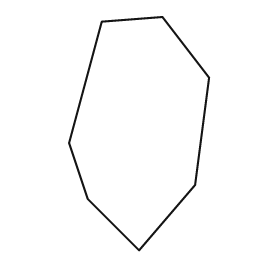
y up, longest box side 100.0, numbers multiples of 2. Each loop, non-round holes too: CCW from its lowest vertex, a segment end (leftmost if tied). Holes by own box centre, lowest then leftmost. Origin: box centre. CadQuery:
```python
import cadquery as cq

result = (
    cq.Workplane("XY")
    .moveTo(0.0, -50.0)
    .lineTo(24.0, -22.0)
    .lineTo(30.0, 24.0)
    .lineTo(10.0, 50.0)
    .lineTo(-16.0, 48.0)
    .lineTo(-30.0, -4.0)
    .lineTo(-22.0, -28.0)
    .close()
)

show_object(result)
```